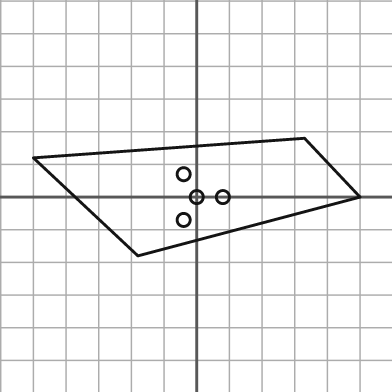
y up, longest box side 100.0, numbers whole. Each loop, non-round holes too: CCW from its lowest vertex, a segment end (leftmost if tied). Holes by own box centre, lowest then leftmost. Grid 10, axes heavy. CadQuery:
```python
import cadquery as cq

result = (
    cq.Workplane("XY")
    .moveTo(-18.0, -18.0)
    .lineTo(50.0, 0.0)
    .lineTo(33.0, 18.0)
    .lineTo(-50.0, 12.0)
    .close()
    .moveTo(-4.0, -7.0)
    .circle(2.0)
    .moveTo(0.0, 0.0)
    .circle(2.0)
    .moveTo(8.0, 0.0)
    .circle(2.0)
    .moveTo(-4.0, 7.0)
    .circle(2.0)
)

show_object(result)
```